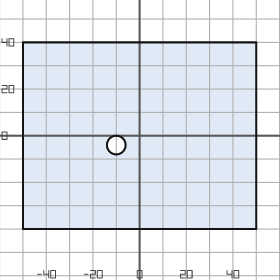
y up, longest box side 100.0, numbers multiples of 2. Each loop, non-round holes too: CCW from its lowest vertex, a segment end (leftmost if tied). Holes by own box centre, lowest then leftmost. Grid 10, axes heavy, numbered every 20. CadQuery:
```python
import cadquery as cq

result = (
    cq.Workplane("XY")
    .moveTo(-50.0, -40.0)
    .lineTo(50.0, -40.0)
    .lineTo(50.0, 40.0)
    .lineTo(-50.0, 40.0)
    .close()
    .moveTo(-10.0, -4.0)
    .circle(4.0)
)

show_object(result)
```